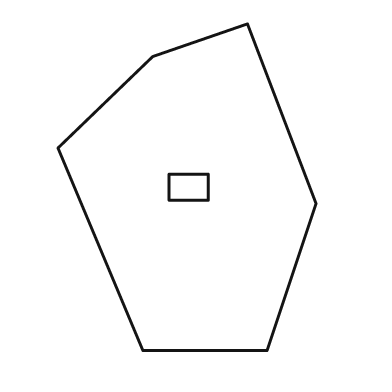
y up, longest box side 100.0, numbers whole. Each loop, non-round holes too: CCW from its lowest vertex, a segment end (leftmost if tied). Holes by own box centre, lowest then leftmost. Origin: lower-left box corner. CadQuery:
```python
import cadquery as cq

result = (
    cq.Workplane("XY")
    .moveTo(26.0, 0.0)
    .lineTo(64.0, 0.0)
    .lineTo(79.0, 45.0)
    .lineTo(58.0, 100.0)
    .lineTo(29.0, 90.0)
    .lineTo(0.0, 62.0)
    .close()
    .moveTo(34.0, 46.0)
    .lineTo(46.0, 46.0)
    .lineTo(46.0, 54.0)
    .lineTo(34.0, 54.0)
    .close()
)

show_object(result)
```